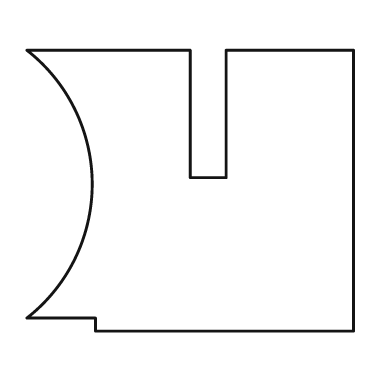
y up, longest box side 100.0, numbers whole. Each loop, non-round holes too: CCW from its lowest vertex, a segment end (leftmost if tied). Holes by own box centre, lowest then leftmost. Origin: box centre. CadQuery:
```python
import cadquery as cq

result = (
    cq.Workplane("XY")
    .moveTo(-29.0, -43.0)
    .lineTo(50.0, -43.0)
    .lineTo(50.0, 43.0)
    .lineTo(11.0, 43.0)
    .lineTo(11.0, 4.0)
    .lineTo(0.0, 4.0)
    .lineTo(0.0, 43.0)
    .lineTo(-50.0, 43.0)
    .threePointArc((-30.0, 2.0), (-50.0, -39.0))
    .lineTo(-29.0, -39.0)
    .close()
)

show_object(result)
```